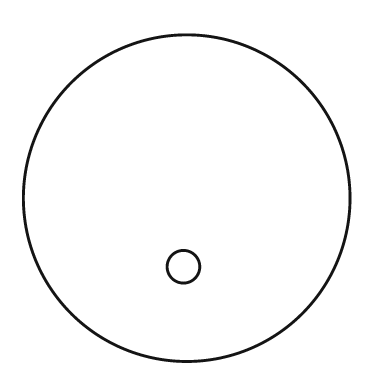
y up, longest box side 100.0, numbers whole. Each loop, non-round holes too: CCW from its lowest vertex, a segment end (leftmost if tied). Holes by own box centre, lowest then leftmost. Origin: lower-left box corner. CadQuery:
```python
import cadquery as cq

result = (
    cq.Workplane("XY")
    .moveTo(50.0, 50.0)
    .circle(50.0)
    .moveTo(49.0, 29.0)
    .circle(5.0)
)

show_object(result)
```